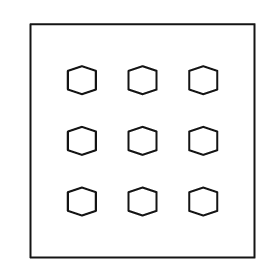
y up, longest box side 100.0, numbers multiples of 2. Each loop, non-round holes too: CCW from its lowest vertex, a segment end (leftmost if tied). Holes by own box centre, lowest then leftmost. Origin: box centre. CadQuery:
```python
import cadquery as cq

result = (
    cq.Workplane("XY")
    .moveTo(-48.0, -50.0)
    .lineTo(48.0, -50.0)
    .lineTo(48.0, 50.0)
    .lineTo(-48.0, 50.0)
    .close()
    .moveTo(-26.0, -32.0)
    .lineTo(-20.0, -30.0)
    .lineTo(-20.0, -22.0)
    .lineTo(-26.0, -20.0)
    .lineTo(-32.0, -22.0)
    .lineTo(-32.0, -30.0)
    .close()
    .moveTo(0.0, -32.0)
    .lineTo(6.0, -30.0)
    .lineTo(6.0, -22.0)
    .lineTo(0.0, -20.0)
    .lineTo(-6.0, -22.0)
    .lineTo(-6.0, -30.0)
    .close()
    .moveTo(26.0, -32.0)
    .lineTo(32.0, -30.0)
    .lineTo(32.0, -22.0)
    .lineTo(26.0, -20.0)
    .lineTo(20.0, -22.0)
    .lineTo(20.0, -30.0)
    .close()
    .moveTo(-26.0, -6.0)
    .lineTo(-20.0, -4.0)
    .lineTo(-20.0, 4.0)
    .lineTo(-26.0, 6.0)
    .lineTo(-32.0, 4.0)
    .lineTo(-32.0, -4.0)
    .close()
    .moveTo(0.0, -6.0)
    .lineTo(6.0, -4.0)
    .lineTo(6.0, 4.0)
    .lineTo(0.0, 6.0)
    .lineTo(-6.0, 4.0)
    .lineTo(-6.0, -4.0)
    .close()
    .moveTo(26.0, -6.0)
    .lineTo(32.0, -4.0)
    .lineTo(32.0, 4.0)
    .lineTo(26.0, 6.0)
    .lineTo(20.0, 4.0)
    .lineTo(20.0, -4.0)
    .close()
    .moveTo(-26.0, 20.0)
    .lineTo(-20.0, 22.0)
    .lineTo(-20.0, 30.0)
    .lineTo(-26.0, 32.0)
    .lineTo(-32.0, 30.0)
    .lineTo(-32.0, 22.0)
    .close()
    .moveTo(0.0, 20.0)
    .lineTo(6.0, 22.0)
    .lineTo(6.0, 30.0)
    .lineTo(0.0, 32.0)
    .lineTo(-6.0, 30.0)
    .lineTo(-6.0, 22.0)
    .close()
    .moveTo(26.0, 20.0)
    .lineTo(32.0, 22.0)
    .lineTo(32.0, 30.0)
    .lineTo(26.0, 32.0)
    .lineTo(20.0, 30.0)
    .lineTo(20.0, 22.0)
    .close()
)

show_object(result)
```